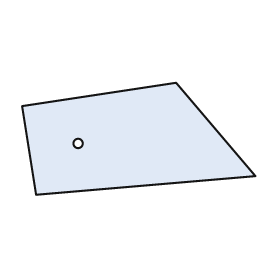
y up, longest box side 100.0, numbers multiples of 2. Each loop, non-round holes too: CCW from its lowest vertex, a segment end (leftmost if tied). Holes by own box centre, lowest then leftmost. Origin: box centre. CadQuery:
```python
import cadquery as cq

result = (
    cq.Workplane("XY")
    .moveTo(-44.0, -24.0)
    .lineTo(50.0, -16.0)
    .lineTo(16.0, 24.0)
    .lineTo(-50.0, 14.0)
    .close()
    .moveTo(-26.0, -2.0)
    .circle(2.0)
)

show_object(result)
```